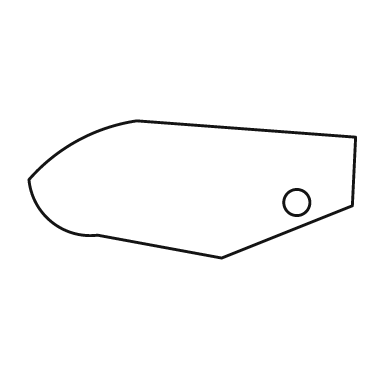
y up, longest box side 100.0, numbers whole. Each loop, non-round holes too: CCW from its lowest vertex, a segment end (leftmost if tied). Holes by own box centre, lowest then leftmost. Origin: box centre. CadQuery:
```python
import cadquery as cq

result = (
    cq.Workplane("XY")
    .moveTo(9.0, -21.0)
    .lineTo(49.0, -5.0)
    .lineTo(50.0, 16.0)
    .lineTo(-17.0, 21.0)
    .threePointArc((-35.0, 15.0), (-50.0, 3.0))
    .threePointArc((-43.0, -10.0), (-29.0, -14.0))
    .close()
    .moveTo(32.0, -4.0)
    .circle(4.0)
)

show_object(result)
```